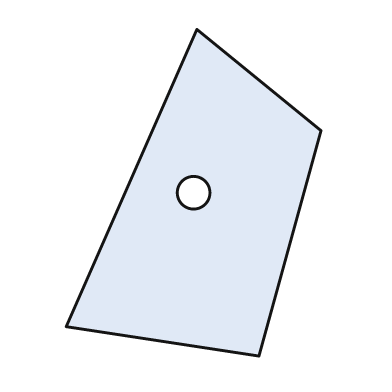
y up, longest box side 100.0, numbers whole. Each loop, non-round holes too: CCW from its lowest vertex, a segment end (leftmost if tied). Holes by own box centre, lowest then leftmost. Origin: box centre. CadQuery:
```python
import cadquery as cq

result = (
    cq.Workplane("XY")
    .moveTo(20.0, -50.0)
    .lineTo(39.0, 19.0)
    .lineTo(1.0, 50.0)
    .lineTo(-39.0, -41.0)
    .close()
    .moveTo(0.0, 0.0)
    .circle(5.0)
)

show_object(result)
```